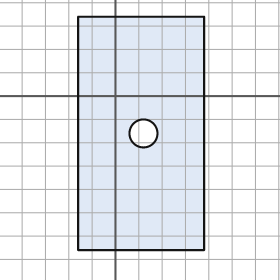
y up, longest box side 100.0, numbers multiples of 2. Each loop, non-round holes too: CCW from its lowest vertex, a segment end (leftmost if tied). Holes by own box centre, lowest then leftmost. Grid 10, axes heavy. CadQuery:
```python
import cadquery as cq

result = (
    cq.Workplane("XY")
    .moveTo(-16.0, -66.0)
    .lineTo(38.0, -66.0)
    .lineTo(38.0, 34.0)
    .lineTo(-16.0, 34.0)
    .close()
    .moveTo(12.0, -16.0)
    .circle(6.0)
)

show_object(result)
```